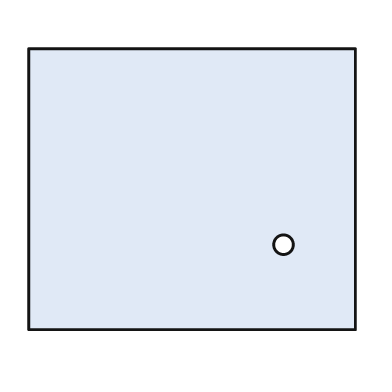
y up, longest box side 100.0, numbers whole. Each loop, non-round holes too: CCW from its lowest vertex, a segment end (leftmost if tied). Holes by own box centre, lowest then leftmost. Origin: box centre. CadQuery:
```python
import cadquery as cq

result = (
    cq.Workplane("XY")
    .moveTo(-50.0, -43.0)
    .lineTo(50.0, -43.0)
    .lineTo(50.0, 43.0)
    .lineTo(-50.0, 43.0)
    .close()
    .moveTo(28.0, -17.0)
    .circle(3.0)
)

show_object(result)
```